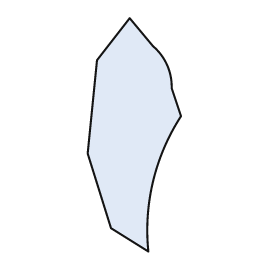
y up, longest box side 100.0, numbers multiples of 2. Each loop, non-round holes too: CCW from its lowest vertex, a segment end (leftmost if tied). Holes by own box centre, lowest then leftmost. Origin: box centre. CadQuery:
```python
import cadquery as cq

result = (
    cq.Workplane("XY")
    .moveTo(6.0, -50.0)
    .threePointArc((8.0, -20.0), (20.0, 8.0))
    .lineTo(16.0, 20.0)
    .threePointArc((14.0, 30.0), (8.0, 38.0))
    .lineTo(-2.0, 50.0)
    .lineTo(-16.0, 32.0)
    .lineTo(-20.0, -8.0)
    .lineTo(-10.0, -40.0)
    .close()
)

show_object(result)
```